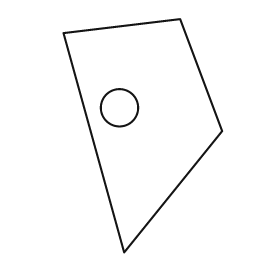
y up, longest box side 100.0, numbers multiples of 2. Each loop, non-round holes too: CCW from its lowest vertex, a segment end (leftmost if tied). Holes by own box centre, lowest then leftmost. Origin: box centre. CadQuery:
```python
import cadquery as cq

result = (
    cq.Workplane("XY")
    .moveTo(-8.0, -50.0)
    .lineTo(34.0, 2.0)
    .lineTo(16.0, 50.0)
    .lineTo(-34.0, 44.0)
    .close()
    .moveTo(-10.0, 12.0)
    .circle(8.0)
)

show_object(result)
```